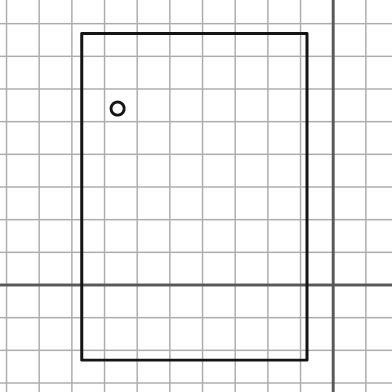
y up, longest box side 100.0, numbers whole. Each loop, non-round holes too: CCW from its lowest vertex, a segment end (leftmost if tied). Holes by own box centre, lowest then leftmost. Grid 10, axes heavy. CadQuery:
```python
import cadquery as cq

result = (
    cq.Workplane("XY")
    .moveTo(-77.0, -23.0)
    .lineTo(-8.0, -23.0)
    .lineTo(-8.0, 77.0)
    .lineTo(-77.0, 77.0)
    .close()
    .moveTo(-66.0, 54.0)
    .circle(2.0)
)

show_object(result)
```